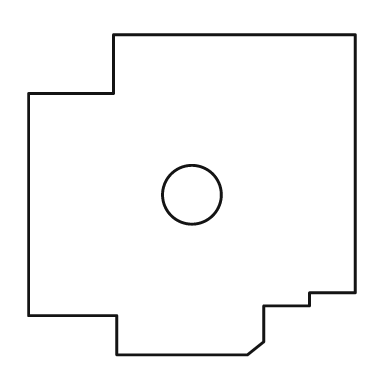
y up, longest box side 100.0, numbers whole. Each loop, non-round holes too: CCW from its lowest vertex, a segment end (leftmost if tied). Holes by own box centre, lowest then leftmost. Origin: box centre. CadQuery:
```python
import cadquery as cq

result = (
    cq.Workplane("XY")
    .moveTo(-23.0, -49.0)
    .lineTo(17.0, -49.0)
    .lineTo(22.0, -45.0)
    .lineTo(22.0, -34.0)
    .lineTo(36.0, -34.0)
    .lineTo(36.0, -30.0)
    .lineTo(50.0, -30.0)
    .lineTo(50.0, 49.0)
    .lineTo(-24.0, 49.0)
    .lineTo(-24.0, 31.0)
    .lineTo(-50.0, 31.0)
    .lineTo(-50.0, -37.0)
    .lineTo(-23.0, -37.0)
    .close()
    .moveTo(0.0, 0.0)
    .circle(9.0)
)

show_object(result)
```